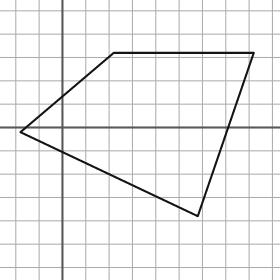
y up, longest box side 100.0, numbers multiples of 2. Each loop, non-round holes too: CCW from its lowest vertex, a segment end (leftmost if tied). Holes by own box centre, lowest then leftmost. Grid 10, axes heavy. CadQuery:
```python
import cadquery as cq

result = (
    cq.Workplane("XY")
    .moveTo(58.0, -38.0)
    .lineTo(82.0, 32.0)
    .lineTo(22.0, 32.0)
    .lineTo(-18.0, -2.0)
    .close()
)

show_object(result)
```